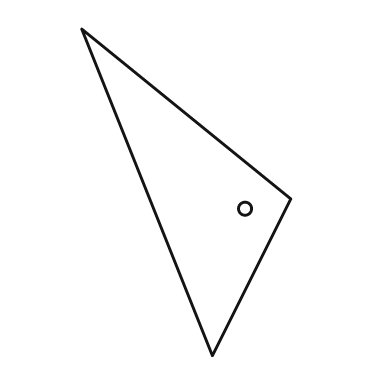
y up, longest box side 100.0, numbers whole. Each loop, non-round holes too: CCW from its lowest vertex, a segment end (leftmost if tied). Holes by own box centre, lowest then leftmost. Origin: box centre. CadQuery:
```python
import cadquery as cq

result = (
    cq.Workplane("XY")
    .moveTo(8.0, -50.0)
    .lineTo(32.0, -2.0)
    .lineTo(-32.0, 50.0)
    .close()
    .moveTo(18.0, -5.0)
    .circle(2.0)
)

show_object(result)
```